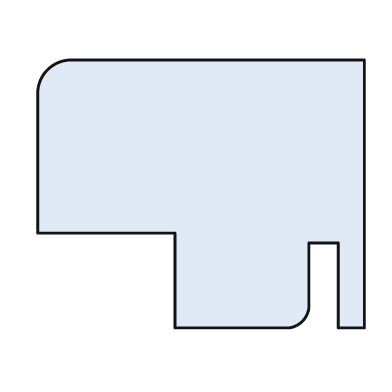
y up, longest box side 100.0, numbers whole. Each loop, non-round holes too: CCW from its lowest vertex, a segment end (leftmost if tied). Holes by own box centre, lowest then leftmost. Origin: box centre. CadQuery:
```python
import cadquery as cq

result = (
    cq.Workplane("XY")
    .moveTo(-8.0, -41.0)
    .lineTo(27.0, -41.0)
    .threePointArc((31.0, -39.0), (33.0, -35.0))
    .lineTo(33.0, -15.0)
    .lineTo(42.0, -15.0)
    .lineTo(42.0, -41.0)
    .lineTo(50.0, -41.0)
    .lineTo(50.0, 41.0)
    .lineTo(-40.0, 41.0)
    .threePointArc((-47.0, 38.0), (-50.0, 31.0))
    .lineTo(-50.0, -12.0)
    .lineTo(-8.0, -12.0)
    .close()
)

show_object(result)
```